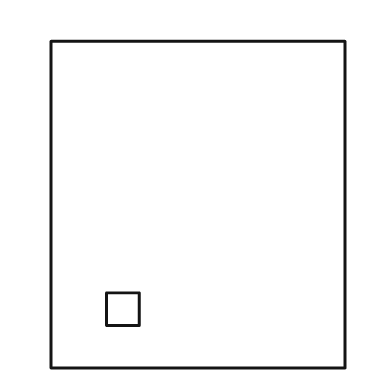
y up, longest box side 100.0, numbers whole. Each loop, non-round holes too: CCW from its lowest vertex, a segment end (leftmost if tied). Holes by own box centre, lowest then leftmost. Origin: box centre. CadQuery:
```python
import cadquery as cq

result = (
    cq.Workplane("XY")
    .moveTo(-45.0, -50.0)
    .lineTo(45.0, -50.0)
    .lineTo(45.0, 50.0)
    .lineTo(-45.0, 50.0)
    .close()
    .moveTo(-28.0, -37.0)
    .lineTo(-18.0, -37.0)
    .lineTo(-18.0, -27.0)
    .lineTo(-28.0, -27.0)
    .close()
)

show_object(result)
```